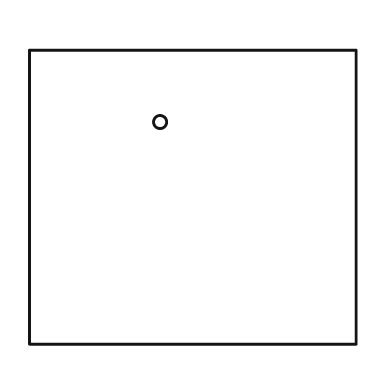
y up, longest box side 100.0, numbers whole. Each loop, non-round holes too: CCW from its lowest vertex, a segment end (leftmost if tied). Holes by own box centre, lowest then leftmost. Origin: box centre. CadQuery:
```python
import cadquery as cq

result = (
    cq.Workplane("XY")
    .moveTo(-50.0, -45.0)
    .lineTo(50.0, -45.0)
    .lineTo(50.0, 45.0)
    .lineTo(-50.0, 45.0)
    .close()
    .moveTo(-10.0, 23.0)
    .circle(2.0)
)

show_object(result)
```